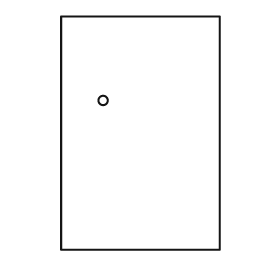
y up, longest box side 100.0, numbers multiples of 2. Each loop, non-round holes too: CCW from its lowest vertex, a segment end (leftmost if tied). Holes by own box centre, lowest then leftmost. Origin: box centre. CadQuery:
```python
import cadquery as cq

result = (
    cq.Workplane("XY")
    .moveTo(-34.0, -50.0)
    .lineTo(34.0, -50.0)
    .lineTo(34.0, 50.0)
    .lineTo(-34.0, 50.0)
    .close()
    .moveTo(-16.0, 14.0)
    .circle(2.0)
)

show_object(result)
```